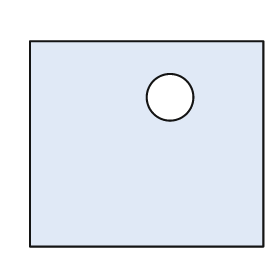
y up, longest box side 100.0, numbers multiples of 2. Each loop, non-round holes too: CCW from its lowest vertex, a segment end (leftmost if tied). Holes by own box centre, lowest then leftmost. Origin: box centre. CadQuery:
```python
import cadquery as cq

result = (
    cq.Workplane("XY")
    .moveTo(-50.0, -44.0)
    .lineTo(50.0, -44.0)
    .lineTo(50.0, 44.0)
    .lineTo(-50.0, 44.0)
    .close()
    .moveTo(10.0, 20.0)
    .circle(10.0)
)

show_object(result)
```